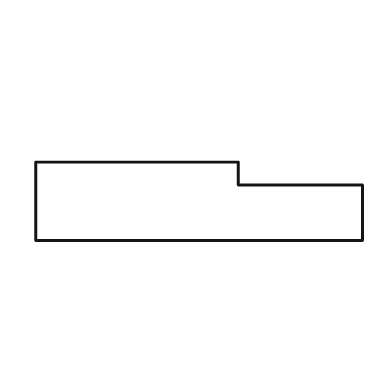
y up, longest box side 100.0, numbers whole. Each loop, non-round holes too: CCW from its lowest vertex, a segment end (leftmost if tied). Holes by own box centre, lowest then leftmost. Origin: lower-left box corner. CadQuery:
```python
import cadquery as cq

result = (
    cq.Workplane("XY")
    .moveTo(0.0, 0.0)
    .lineTo(100.0, 0.0)
    .lineTo(100.0, 17.0)
    .lineTo(62.0, 17.0)
    .lineTo(62.0, 24.0)
    .lineTo(0.0, 24.0)
    .close()
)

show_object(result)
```